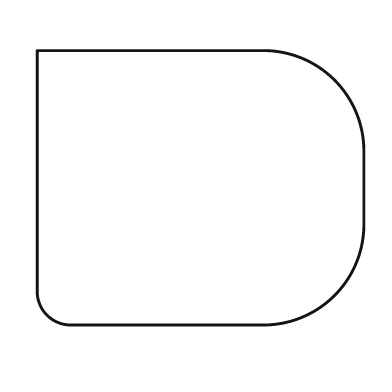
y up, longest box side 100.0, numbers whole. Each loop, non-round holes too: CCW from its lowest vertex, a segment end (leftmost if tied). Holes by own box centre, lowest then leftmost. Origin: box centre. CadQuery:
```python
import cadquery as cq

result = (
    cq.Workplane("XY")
    .moveTo(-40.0, -42.0)
    .lineTo(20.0, -42.0)
    .threePointArc((41.0, -33.0), (50.0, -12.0))
    .lineTo(50.0, 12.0)
    .threePointArc((41.0, 33.0), (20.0, 42.0))
    .lineTo(-50.0, 42.0)
    .lineTo(-50.0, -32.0)
    .threePointArc((-47.0, -39.0), (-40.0, -42.0))
    .close()
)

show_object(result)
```